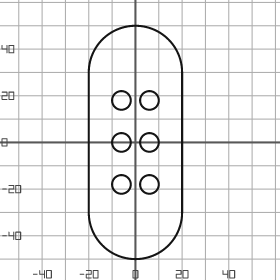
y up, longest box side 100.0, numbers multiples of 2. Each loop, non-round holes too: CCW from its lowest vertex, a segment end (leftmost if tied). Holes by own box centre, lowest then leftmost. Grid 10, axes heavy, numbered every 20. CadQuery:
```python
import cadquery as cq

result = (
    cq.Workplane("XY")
    .moveTo(-20.0, -30.0)
    .threePointArc((0.0, -50.0), (20.0, -30.0))
    .lineTo(20.0, 30.0)
    .threePointArc((0.0, 50.0), (-20.0, 30.0))
    .close()
    .moveTo(-6.0, -18.0)
    .circle(4.0)
    .moveTo(6.0, -18.0)
    .circle(4.0)
    .moveTo(-6.0, 0.0)
    .circle(4.0)
    .moveTo(6.0, 0.0)
    .circle(4.0)
    .moveTo(-6.0, 18.0)
    .circle(4.0)
    .moveTo(6.0, 18.0)
    .circle(4.0)
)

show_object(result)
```